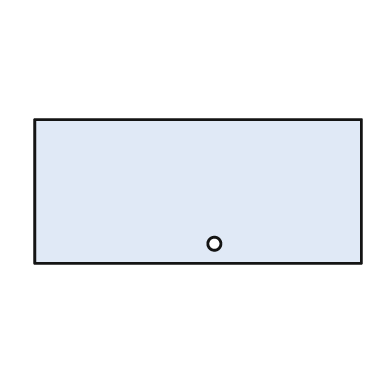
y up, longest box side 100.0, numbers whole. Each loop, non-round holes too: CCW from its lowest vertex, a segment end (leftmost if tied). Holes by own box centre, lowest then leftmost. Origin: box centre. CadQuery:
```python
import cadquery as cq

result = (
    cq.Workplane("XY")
    .moveTo(-50.0, -22.0)
    .lineTo(50.0, -22.0)
    .lineTo(50.0, 22.0)
    .lineTo(-50.0, 22.0)
    .close()
    .moveTo(5.0, -16.0)
    .circle(2.0)
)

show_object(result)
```